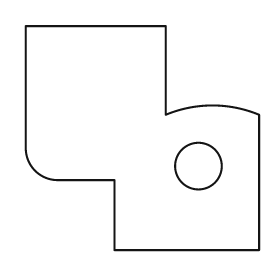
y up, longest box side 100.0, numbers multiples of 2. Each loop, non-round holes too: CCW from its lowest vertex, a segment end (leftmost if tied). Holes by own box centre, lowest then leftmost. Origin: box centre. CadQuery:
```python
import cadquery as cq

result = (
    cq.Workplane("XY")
    .moveTo(-12.0, -48.0)
    .lineTo(50.0, -48.0)
    .lineTo(50.0, 10.0)
    .threePointArc((30.0, 14.0), (10.0, 10.0))
    .lineTo(10.0, 48.0)
    .lineTo(-50.0, 48.0)
    .lineTo(-50.0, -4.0)
    .threePointArc((-46.0, -14.0), (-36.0, -18.0))
    .lineTo(-12.0, -18.0)
    .close()
    .moveTo(24.0, -12.0)
    .circle(10.0)
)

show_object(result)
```